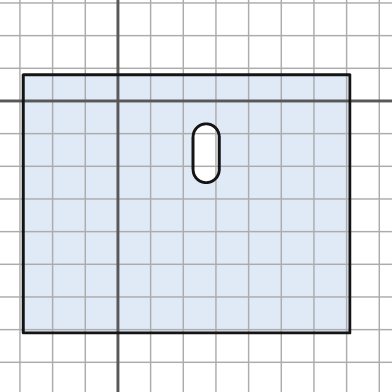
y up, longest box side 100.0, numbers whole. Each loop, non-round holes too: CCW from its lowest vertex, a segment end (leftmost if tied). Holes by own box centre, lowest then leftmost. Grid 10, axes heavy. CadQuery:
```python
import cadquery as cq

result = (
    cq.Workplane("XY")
    .moveTo(-29.0, -71.0)
    .lineTo(71.0, -71.0)
    .lineTo(71.0, 8.0)
    .lineTo(-29.0, 8.0)
    .close()
    .moveTo(23.0, -21.0)
    .threePointArc((27.0, -25.0), (31.0, -21.0))
    .lineTo(31.0, -11.0)
    .threePointArc((27.0, -7.0), (23.0, -11.0))
    .close()
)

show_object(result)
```